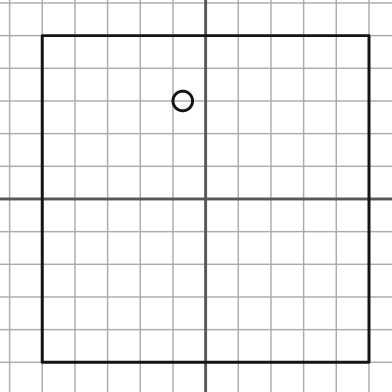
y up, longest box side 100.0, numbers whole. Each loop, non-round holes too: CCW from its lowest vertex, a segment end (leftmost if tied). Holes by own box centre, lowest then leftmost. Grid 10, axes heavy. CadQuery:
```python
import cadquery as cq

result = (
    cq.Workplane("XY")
    .moveTo(-50.0, -50.0)
    .lineTo(50.0, -50.0)
    .lineTo(50.0, 50.0)
    .lineTo(-50.0, 50.0)
    .close()
    .moveTo(-7.0, 30.0)
    .circle(3.0)
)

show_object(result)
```